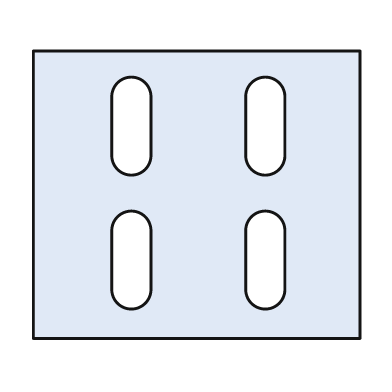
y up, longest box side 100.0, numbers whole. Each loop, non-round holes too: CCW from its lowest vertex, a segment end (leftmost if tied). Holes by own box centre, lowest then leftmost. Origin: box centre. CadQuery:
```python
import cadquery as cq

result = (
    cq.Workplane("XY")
    .moveTo(-50.0, -44.0)
    .lineTo(50.0, -44.0)
    .lineTo(50.0, 44.0)
    .lineTo(-50.0, 44.0)
    .close()
    .moveTo(-26.0, -29.0)
    .threePointArc((-20.0, -35.0), (-14.0, -29.0))
    .lineTo(-14.0, -11.0)
    .threePointArc((-20.0, -5.0), (-26.0, -11.0))
    .close()
    .moveTo(15.0, -29.0)
    .threePointArc((21.0, -35.0), (27.0, -29.0))
    .lineTo(27.0, -11.0)
    .threePointArc((21.0, -5.0), (15.0, -11.0))
    .close()
    .moveTo(-26.0, 12.0)
    .threePointArc((-20.0, 6.0), (-14.0, 12.0))
    .lineTo(-14.0, 30.0)
    .threePointArc((-20.0, 36.0), (-26.0, 30.0))
    .close()
    .moveTo(15.0, 12.0)
    .threePointArc((21.0, 6.0), (27.0, 12.0))
    .lineTo(27.0, 30.0)
    .threePointArc((21.0, 36.0), (15.0, 30.0))
    .close()
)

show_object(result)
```